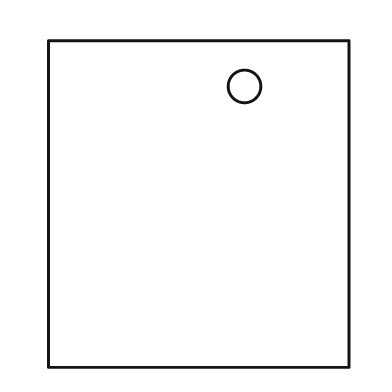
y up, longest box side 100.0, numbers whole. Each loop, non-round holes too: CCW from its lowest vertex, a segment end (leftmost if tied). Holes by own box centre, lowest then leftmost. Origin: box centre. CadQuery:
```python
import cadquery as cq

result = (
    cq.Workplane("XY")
    .moveTo(-46.0, -50.0)
    .lineTo(46.0, -50.0)
    .lineTo(46.0, 50.0)
    .lineTo(-46.0, 50.0)
    .close()
    .moveTo(14.0, 36.0)
    .circle(5.0)
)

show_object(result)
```